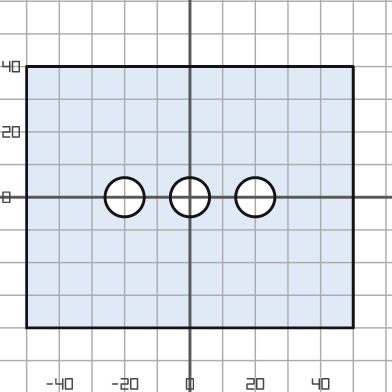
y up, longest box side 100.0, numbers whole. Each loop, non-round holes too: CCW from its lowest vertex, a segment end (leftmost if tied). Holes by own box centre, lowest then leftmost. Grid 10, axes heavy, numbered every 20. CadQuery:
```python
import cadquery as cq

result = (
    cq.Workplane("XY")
    .moveTo(-50.0, -40.0)
    .lineTo(50.0, -40.0)
    .lineTo(50.0, 40.0)
    .lineTo(-50.0, 40.0)
    .close()
    .moveTo(-20.0, 0.0)
    .circle(6.0)
    .moveTo(0.0, 0.0)
    .circle(6.0)
    .moveTo(20.0, 0.0)
    .circle(6.0)
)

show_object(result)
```